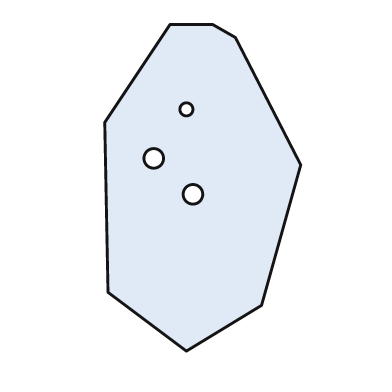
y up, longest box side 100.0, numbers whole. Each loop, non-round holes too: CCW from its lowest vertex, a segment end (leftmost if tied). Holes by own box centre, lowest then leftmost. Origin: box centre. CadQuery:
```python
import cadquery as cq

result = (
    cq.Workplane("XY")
    .moveTo(-5.0, -50.0)
    .lineTo(18.0, -36.0)
    .lineTo(30.0, 7.0)
    .lineTo(10.0, 46.0)
    .lineTo(3.0, 50.0)
    .lineTo(-10.0, 50.0)
    .lineTo(-30.0, 20.0)
    .lineTo(-29.0, -32.0)
    .close()
    .moveTo(-3.0, -2.0)
    .circle(3.0)
    .moveTo(-15.0, 9.0)
    .circle(3.0)
    .moveTo(-5.0, 24.0)
    .circle(2.0)
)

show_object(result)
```